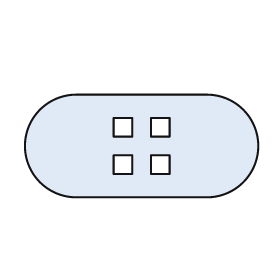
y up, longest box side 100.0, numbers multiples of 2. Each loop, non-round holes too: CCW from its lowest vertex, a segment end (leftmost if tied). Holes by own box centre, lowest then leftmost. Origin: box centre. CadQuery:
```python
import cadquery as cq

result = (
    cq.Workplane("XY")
    .moveTo(-28.0, -22.0)
    .lineTo(28.0, -22.0)
    .threePointArc((50.0, 0.0), (28.0, 22.0))
    .lineTo(-28.0, 22.0)
    .threePointArc((-50.0, 0.0), (-28.0, -22.0))
    .close()
    .moveTo(-12.0, -12.0)
    .lineTo(-4.0, -12.0)
    .lineTo(-4.0, -4.0)
    .lineTo(-12.0, -4.0)
    .close()
    .moveTo(4.0, -12.0)
    .lineTo(12.0, -12.0)
    .lineTo(12.0, -4.0)
    .lineTo(4.0, -4.0)
    .close()
    .moveTo(-12.0, 4.0)
    .lineTo(-4.0, 4.0)
    .lineTo(-4.0, 12.0)
    .lineTo(-12.0, 12.0)
    .close()
    .moveTo(4.0, 4.0)
    .lineTo(12.0, 4.0)
    .lineTo(12.0, 12.0)
    .lineTo(4.0, 12.0)
    .close()
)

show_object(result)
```